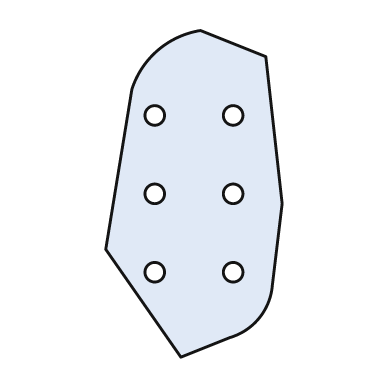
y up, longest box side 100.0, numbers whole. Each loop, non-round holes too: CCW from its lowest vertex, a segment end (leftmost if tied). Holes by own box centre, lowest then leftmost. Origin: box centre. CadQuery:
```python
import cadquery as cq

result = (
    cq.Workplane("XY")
    .moveTo(-4.0, -50.0)
    .lineTo(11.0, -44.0)
    .threePointArc((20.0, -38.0), (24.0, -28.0))
    .lineTo(27.0, -3.0)
    .lineTo(22.0, 42.0)
    .lineTo(2.0, 50.0)
    .threePointArc((-11.0, 44.0), (-19.0, 32.0))
    .lineTo(-27.0, -17.0)
    .close()
    .moveTo(-12.0, -24.0)
    .circle(3.0)
    .moveTo(12.0, -24.0)
    .circle(3.0)
    .moveTo(-12.0, 0.0)
    .circle(3.0)
    .moveTo(12.0, 0.0)
    .circle(3.0)
    .moveTo(-12.0, 24.0)
    .circle(3.0)
    .moveTo(12.0, 24.0)
    .circle(3.0)
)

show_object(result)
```